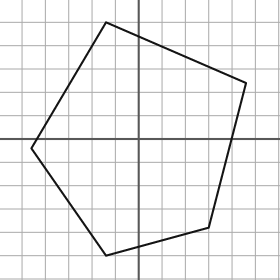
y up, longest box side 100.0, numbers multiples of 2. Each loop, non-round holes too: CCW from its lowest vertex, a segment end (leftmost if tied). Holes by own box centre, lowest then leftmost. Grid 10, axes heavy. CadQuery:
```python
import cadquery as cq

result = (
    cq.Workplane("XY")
    .moveTo(-14.0, -50.0)
    .lineTo(30.0, -38.0)
    .lineTo(46.0, 24.0)
    .lineTo(-14.0, 50.0)
    .lineTo(-46.0, -4.0)
    .close()
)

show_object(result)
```